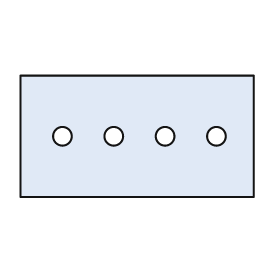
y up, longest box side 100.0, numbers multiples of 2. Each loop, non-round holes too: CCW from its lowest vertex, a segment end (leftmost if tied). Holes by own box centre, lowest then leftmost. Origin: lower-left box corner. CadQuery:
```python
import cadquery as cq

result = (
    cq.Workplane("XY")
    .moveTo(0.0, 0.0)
    .lineTo(100.0, 0.0)
    .lineTo(100.0, 52.0)
    .lineTo(0.0, 52.0)
    .close()
    .moveTo(18.0, 26.0)
    .circle(4.0)
    .moveTo(40.0, 26.0)
    .circle(4.0)
    .moveTo(62.0, 26.0)
    .circle(4.0)
    .moveTo(84.0, 26.0)
    .circle(4.0)
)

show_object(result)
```